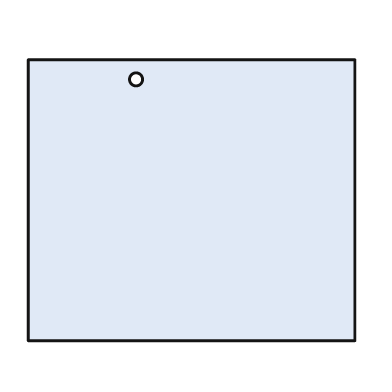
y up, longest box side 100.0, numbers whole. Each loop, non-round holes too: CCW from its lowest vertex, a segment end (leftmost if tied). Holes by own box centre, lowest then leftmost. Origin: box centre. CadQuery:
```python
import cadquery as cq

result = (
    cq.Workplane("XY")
    .moveTo(-50.0, -43.0)
    .lineTo(50.0, -43.0)
    .lineTo(50.0, 43.0)
    .lineTo(-50.0, 43.0)
    .close()
    .moveTo(-17.0, 37.0)
    .circle(2.0)
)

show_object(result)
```